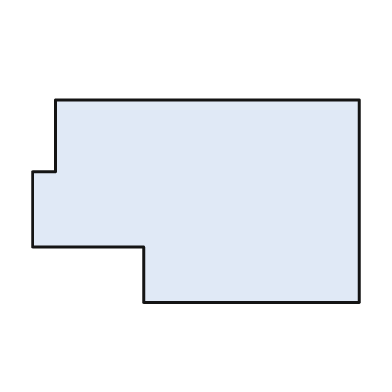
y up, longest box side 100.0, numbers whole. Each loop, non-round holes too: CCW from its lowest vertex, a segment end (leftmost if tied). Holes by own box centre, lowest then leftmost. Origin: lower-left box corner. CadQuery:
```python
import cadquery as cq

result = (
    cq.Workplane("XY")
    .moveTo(34.0, 0.0)
    .lineTo(100.0, 0.0)
    .lineTo(100.0, 62.0)
    .lineTo(7.0, 62.0)
    .lineTo(7.0, 40.0)
    .lineTo(0.0, 40.0)
    .lineTo(0.0, 17.0)
    .lineTo(34.0, 17.0)
    .close()
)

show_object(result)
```